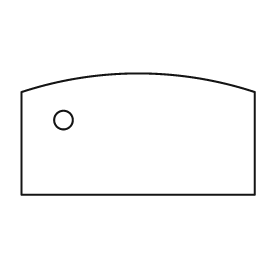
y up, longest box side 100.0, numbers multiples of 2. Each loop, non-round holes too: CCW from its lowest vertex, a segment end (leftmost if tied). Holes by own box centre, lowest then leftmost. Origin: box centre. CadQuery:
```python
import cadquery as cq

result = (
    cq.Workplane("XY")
    .moveTo(-50.0, -26.0)
    .lineTo(50.0, -26.0)
    .lineTo(50.0, 18.0)
    .threePointArc((0.0, 26.0), (-50.0, 18.0))
    .close()
    .moveTo(-32.0, 6.0)
    .circle(4.0)
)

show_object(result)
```